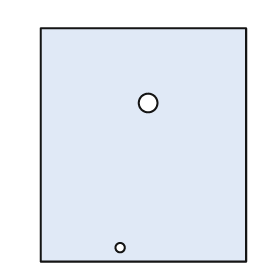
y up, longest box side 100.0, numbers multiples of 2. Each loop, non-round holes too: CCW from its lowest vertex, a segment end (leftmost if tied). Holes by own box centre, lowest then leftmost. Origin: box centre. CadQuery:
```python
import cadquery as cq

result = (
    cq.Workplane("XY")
    .moveTo(-44.0, -50.0)
    .lineTo(44.0, -50.0)
    .lineTo(44.0, 50.0)
    .lineTo(-44.0, 50.0)
    .close()
    .moveTo(-10.0, -44.0)
    .circle(2.0)
    .moveTo(2.0, 18.0)
    .circle(4.0)
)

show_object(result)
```